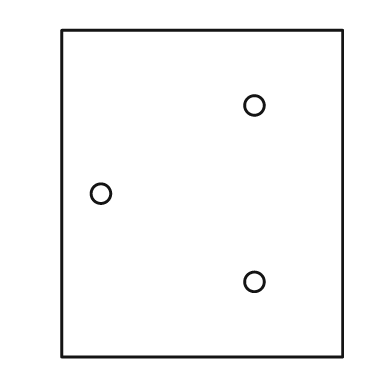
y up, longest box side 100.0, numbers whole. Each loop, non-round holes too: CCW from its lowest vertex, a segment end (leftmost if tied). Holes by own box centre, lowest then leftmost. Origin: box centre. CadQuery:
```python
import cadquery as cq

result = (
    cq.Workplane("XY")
    .moveTo(-43.0, -50.0)
    .lineTo(43.0, -50.0)
    .lineTo(43.0, 50.0)
    .lineTo(-43.0, 50.0)
    .close()
    .moveTo(16.0, -27.0)
    .circle(3.0)
    .moveTo(-31.0, 0.0)
    .circle(3.0)
    .moveTo(16.0, 27.0)
    .circle(3.0)
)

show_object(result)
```